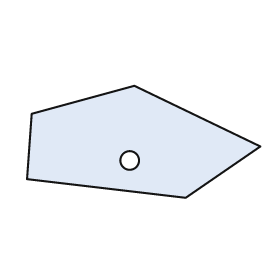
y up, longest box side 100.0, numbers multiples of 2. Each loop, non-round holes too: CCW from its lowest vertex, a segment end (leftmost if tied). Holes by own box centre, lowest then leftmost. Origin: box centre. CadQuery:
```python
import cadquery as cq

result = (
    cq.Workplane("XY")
    .moveTo(18.0, -24.0)
    .lineTo(50.0, -2.0)
    .lineTo(-4.0, 24.0)
    .lineTo(-48.0, 12.0)
    .lineTo(-50.0, -16.0)
    .close()
    .moveTo(-6.0, -8.0)
    .circle(4.0)
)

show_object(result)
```